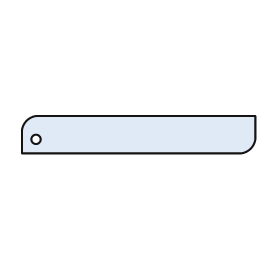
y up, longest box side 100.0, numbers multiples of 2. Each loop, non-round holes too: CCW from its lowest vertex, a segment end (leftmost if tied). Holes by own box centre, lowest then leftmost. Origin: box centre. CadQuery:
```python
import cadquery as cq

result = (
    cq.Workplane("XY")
    .moveTo(-50.0, -8.0)
    .lineTo(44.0, -8.0)
    .threePointArc((48.0, -6.0), (50.0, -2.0))
    .lineTo(50.0, 8.0)
    .lineTo(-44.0, 8.0)
    .threePointArc((-48.0, 6.0), (-50.0, 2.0))
    .close()
    .moveTo(-44.0, -2.0)
    .circle(2.0)
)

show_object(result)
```